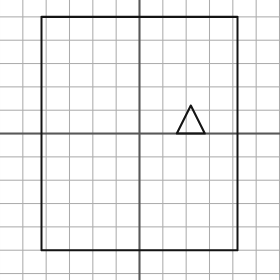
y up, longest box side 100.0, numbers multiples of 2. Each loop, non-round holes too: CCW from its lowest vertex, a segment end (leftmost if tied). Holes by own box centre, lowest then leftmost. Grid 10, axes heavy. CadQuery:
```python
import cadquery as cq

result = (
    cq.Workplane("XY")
    .moveTo(-42.0, -50.0)
    .lineTo(42.0, -50.0)
    .lineTo(42.0, 50.0)
    .lineTo(-42.0, 50.0)
    .close()
    .moveTo(16.0, 0.0)
    .lineTo(28.0, 0.0)
    .lineTo(22.0, 12.0)
    .close()
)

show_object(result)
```